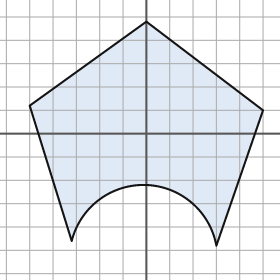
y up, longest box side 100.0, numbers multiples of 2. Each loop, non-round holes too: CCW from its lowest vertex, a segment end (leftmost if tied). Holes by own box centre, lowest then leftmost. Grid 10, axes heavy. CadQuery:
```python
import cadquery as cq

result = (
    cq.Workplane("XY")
    .moveTo(30.0, -48.0)
    .lineTo(50.0, 10.0)
    .lineTo(0.0, 48.0)
    .lineTo(-50.0, 12.0)
    .lineTo(-32.0, -46.0)
    .threePointArc((0.0, -22.0), (30.0, -48.0))
    .close()
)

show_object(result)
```